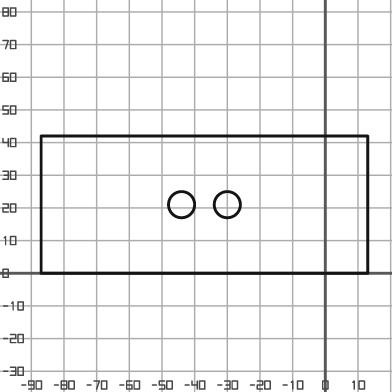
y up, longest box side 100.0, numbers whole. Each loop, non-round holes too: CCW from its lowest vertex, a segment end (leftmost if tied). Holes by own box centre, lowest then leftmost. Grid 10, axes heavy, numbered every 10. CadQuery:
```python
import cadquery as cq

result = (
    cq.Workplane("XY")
    .moveTo(-87.0, 0.0)
    .lineTo(13.0, 0.0)
    .lineTo(13.0, 42.0)
    .lineTo(-87.0, 42.0)
    .close()
    .moveTo(-44.0, 21.0)
    .circle(4.0)
    .moveTo(-30.0, 21.0)
    .circle(4.0)
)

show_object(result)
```